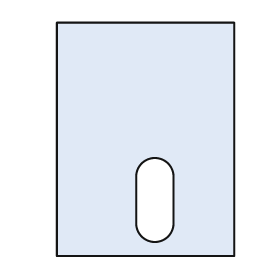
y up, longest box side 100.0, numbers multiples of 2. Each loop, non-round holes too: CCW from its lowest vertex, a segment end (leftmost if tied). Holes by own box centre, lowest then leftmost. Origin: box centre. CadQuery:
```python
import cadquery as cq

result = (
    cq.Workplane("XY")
    .moveTo(-38.0, -50.0)
    .lineTo(38.0, -50.0)
    .lineTo(38.0, 50.0)
    .lineTo(-38.0, 50.0)
    .close()
    .moveTo(-4.0, -36.0)
    .threePointArc((4.0, -44.0), (12.0, -36.0))
    .lineTo(12.0, -16.0)
    .threePointArc((4.0, -8.0), (-4.0, -16.0))
    .close()
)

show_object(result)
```